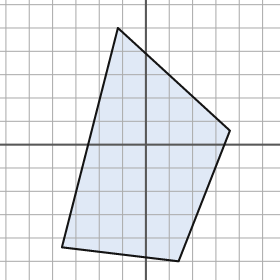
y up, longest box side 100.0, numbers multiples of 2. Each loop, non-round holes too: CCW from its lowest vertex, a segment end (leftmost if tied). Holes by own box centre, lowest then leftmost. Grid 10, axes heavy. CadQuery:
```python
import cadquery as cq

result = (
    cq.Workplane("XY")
    .moveTo(14.0, -50.0)
    .lineTo(36.0, 6.0)
    .lineTo(-12.0, 50.0)
    .lineTo(-36.0, -44.0)
    .close()
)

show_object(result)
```